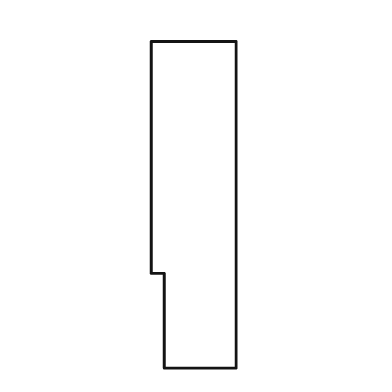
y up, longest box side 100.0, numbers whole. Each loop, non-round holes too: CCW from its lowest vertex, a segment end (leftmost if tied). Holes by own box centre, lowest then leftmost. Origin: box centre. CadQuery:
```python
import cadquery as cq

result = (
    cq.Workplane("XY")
    .moveTo(-9.0, -50.0)
    .lineTo(13.0, -50.0)
    .lineTo(13.0, 50.0)
    .lineTo(-13.0, 50.0)
    .lineTo(-13.0, -21.0)
    .lineTo(-9.0, -21.0)
    .close()
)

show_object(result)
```